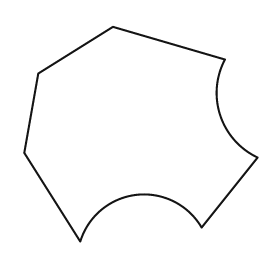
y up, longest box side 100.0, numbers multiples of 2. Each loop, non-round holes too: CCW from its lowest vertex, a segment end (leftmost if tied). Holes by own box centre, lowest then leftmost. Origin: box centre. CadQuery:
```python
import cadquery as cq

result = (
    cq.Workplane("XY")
    .moveTo(-26.0, -46.0)
    .threePointArc((-2.0, -26.0), (26.0, -40.0))
    .lineTo(50.0, -10.0)
    .threePointArc((34.0, 8.0), (36.0, 32.0))
    .lineTo(-12.0, 46.0)
    .lineTo(-44.0, 26.0)
    .lineTo(-50.0, -8.0)
    .close()
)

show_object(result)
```